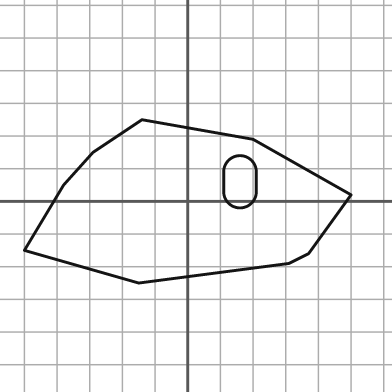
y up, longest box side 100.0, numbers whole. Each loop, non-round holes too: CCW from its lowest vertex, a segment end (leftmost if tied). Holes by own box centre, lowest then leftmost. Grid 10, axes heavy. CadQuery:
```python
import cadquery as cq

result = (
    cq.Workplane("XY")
    .moveTo(-15.0, -25.0)
    .lineTo(31.0, -19.0)
    .lineTo(37.0, -16.0)
    .lineTo(50.0, 2.0)
    .lineTo(20.0, 19.0)
    .lineTo(-14.0, 25.0)
    .lineTo(-29.0, 15.0)
    .lineTo(-38.0, 5.0)
    .lineTo(-50.0, -15.0)
    .close()
    .moveTo(11.0, 3.0)
    .threePointArc((16.0, -2.0), (21.0, 3.0))
    .lineTo(21.0, 9.0)
    .threePointArc((16.0, 14.0), (11.0, 9.0))
    .close()
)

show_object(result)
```